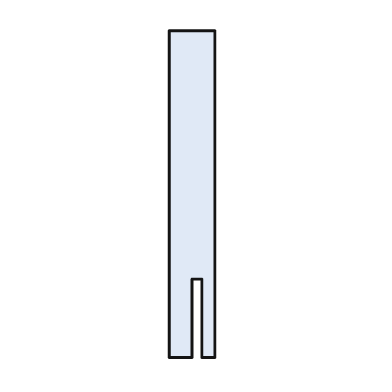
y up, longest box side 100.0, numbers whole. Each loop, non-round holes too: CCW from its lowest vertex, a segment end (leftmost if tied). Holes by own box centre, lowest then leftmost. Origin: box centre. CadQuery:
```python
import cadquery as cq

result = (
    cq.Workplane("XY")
    .moveTo(-7.0, -50.0)
    .lineTo(0.0, -50.0)
    .lineTo(0.0, -26.0)
    .lineTo(3.0, -26.0)
    .lineTo(3.0, -50.0)
    .lineTo(7.0, -50.0)
    .lineTo(7.0, 50.0)
    .lineTo(-7.0, 50.0)
    .close()
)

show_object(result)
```